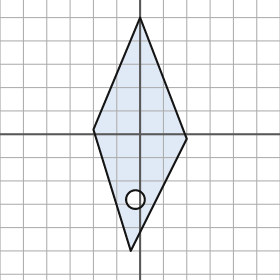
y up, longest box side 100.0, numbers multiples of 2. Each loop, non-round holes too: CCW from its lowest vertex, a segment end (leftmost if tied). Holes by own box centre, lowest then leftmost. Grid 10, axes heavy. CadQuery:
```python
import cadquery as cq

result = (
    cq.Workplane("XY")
    .moveTo(-4.0, -50.0)
    .lineTo(20.0, -2.0)
    .lineTo(0.0, 50.0)
    .lineTo(-20.0, 2.0)
    .close()
    .moveTo(-2.0, -28.0)
    .circle(4.0)
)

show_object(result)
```